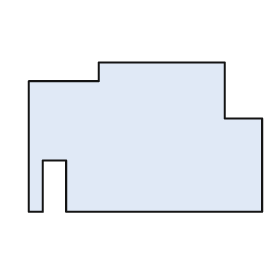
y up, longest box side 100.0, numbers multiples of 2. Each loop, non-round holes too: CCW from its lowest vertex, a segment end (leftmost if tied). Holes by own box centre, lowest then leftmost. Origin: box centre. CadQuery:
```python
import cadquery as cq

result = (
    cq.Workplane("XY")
    .moveTo(-50.0, -32.0)
    .lineTo(-44.0, -32.0)
    .lineTo(-44.0, -10.0)
    .lineTo(-34.0, -10.0)
    .lineTo(-34.0, -32.0)
    .lineTo(50.0, -32.0)
    .lineTo(50.0, 8.0)
    .lineTo(34.0, 8.0)
    .lineTo(34.0, 32.0)
    .lineTo(-20.0, 32.0)
    .lineTo(-20.0, 24.0)
    .lineTo(-50.0, 24.0)
    .close()
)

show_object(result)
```